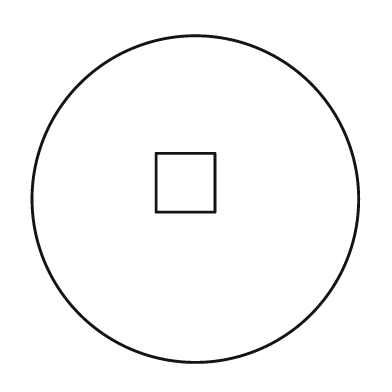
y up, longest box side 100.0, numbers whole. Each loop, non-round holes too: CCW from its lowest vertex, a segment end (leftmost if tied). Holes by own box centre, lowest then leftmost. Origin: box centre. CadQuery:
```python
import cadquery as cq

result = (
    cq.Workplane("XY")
    .moveTo(0.0, 0.0)
    .circle(50.0)
    .moveTo(-12.0, -4.0)
    .lineTo(6.0, -4.0)
    .lineTo(6.0, 14.0)
    .lineTo(-12.0, 14.0)
    .close()
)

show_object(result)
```